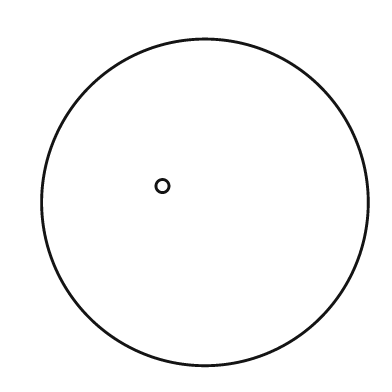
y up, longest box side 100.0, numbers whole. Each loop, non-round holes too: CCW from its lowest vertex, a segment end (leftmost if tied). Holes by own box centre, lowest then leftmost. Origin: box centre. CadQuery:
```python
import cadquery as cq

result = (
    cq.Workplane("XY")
    .moveTo(0.0, 0.0)
    .circle(50.0)
    .moveTo(-13.0, 5.0)
    .circle(2.0)
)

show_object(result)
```